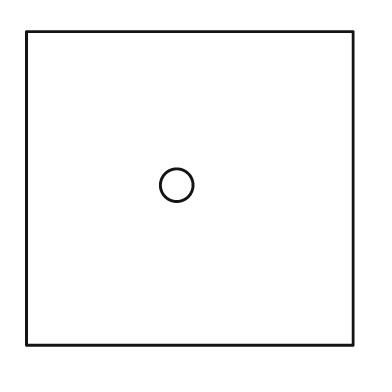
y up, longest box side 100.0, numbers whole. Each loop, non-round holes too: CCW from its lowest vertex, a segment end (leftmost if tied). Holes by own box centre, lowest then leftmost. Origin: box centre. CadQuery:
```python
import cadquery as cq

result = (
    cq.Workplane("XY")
    .moveTo(-50.0, -48.0)
    .lineTo(50.0, -48.0)
    .lineTo(50.0, 48.0)
    .lineTo(-50.0, 48.0)
    .close()
    .moveTo(-4.0, 1.0)
    .circle(5.0)
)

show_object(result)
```